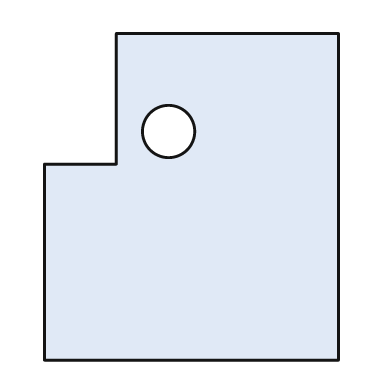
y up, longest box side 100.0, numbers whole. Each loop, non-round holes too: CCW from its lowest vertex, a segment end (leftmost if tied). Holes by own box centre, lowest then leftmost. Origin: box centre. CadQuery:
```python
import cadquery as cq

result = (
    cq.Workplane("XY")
    .moveTo(-45.0, -50.0)
    .lineTo(45.0, -50.0)
    .lineTo(45.0, 50.0)
    .lineTo(-23.0, 50.0)
    .lineTo(-23.0, 10.0)
    .lineTo(-45.0, 10.0)
    .close()
    .moveTo(-7.0, 20.0)
    .circle(8.0)
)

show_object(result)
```